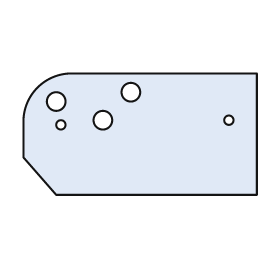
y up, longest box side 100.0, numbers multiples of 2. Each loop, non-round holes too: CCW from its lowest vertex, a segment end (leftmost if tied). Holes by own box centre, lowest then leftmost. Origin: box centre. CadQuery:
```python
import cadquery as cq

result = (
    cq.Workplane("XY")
    .moveTo(-36.0, -26.0)
    .lineTo(50.0, -26.0)
    .lineTo(50.0, 26.0)
    .lineTo(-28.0, 26.0)
    .threePointArc((-44.0, 20.0), (-50.0, 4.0))
    .lineTo(-50.0, -10.0)
    .close()
    .moveTo(-34.0, 4.0)
    .circle(2.0)
    .moveTo(-16.0, 6.0)
    .circle(4.0)
    .moveTo(38.0, 6.0)
    .circle(2.0)
    .moveTo(-36.0, 14.0)
    .circle(4.0)
    .moveTo(-4.0, 18.0)
    .circle(4.0)
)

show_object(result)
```